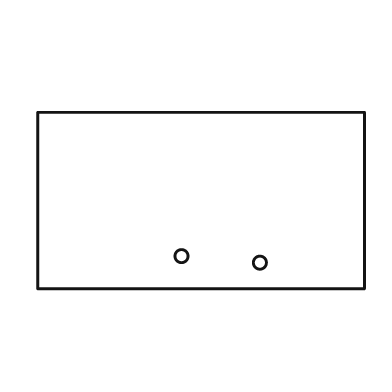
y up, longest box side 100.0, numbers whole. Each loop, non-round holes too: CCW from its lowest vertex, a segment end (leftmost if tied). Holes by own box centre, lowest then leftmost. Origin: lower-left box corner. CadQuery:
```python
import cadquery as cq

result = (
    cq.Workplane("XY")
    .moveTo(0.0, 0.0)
    .lineTo(100.0, 0.0)
    .lineTo(100.0, 54.0)
    .lineTo(0.0, 54.0)
    .close()
    .moveTo(68.0, 8.0)
    .circle(2.0)
    .moveTo(44.0, 10.0)
    .circle(2.0)
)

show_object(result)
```